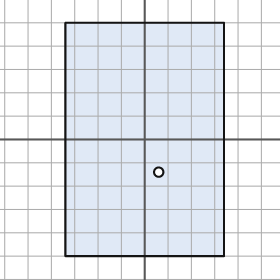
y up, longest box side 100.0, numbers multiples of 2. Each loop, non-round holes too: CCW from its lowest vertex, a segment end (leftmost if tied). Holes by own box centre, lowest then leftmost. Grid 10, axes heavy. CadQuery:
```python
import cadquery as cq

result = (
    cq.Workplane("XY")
    .moveTo(-34.0, -50.0)
    .lineTo(34.0, -50.0)
    .lineTo(34.0, 50.0)
    .lineTo(-34.0, 50.0)
    .close()
    .moveTo(6.0, -14.0)
    .circle(2.0)
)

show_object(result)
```